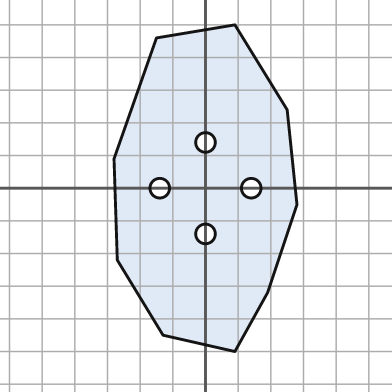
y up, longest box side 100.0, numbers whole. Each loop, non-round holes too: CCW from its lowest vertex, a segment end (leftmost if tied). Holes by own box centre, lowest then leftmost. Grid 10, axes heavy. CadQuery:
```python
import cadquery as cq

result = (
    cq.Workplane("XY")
    .moveTo(9.0, -50.0)
    .lineTo(19.0, -32.0)
    .lineTo(28.0, -5.0)
    .lineTo(25.0, 24.0)
    .lineTo(9.0, 50.0)
    .lineTo(-15.0, 46.0)
    .lineTo(-28.0, 9.0)
    .lineTo(-27.0, -22.0)
    .lineTo(-13.0, -45.0)
    .close()
    .moveTo(0.0, -14.0)
    .circle(3.0)
    .moveTo(-14.0, 0.0)
    .circle(3.0)
    .moveTo(14.0, 0.0)
    .circle(3.0)
    .moveTo(0.0, 14.0)
    .circle(3.0)
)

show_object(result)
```